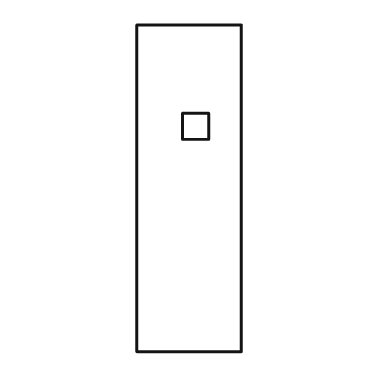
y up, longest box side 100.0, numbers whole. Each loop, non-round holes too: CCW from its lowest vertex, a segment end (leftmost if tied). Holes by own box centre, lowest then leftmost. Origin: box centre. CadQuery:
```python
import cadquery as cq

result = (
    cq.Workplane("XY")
    .moveTo(-16.0, -50.0)
    .lineTo(16.0, -50.0)
    .lineTo(16.0, 50.0)
    .lineTo(-16.0, 50.0)
    .close()
    .moveTo(-2.0, 15.0)
    .lineTo(6.0, 15.0)
    .lineTo(6.0, 23.0)
    .lineTo(-2.0, 23.0)
    .close()
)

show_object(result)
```